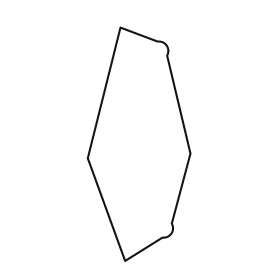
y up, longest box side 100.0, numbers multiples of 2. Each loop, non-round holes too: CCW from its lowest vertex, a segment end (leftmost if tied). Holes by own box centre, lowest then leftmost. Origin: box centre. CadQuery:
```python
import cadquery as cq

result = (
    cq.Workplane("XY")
    .moveTo(-6.0, -50.0)
    .lineTo(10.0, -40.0)
    .threePointArc((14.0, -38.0), (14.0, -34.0))
    .lineTo(22.0, -4.0)
    .lineTo(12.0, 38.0)
    .threePointArc((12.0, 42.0), (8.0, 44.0))
    .lineTo(-8.0, 50.0)
    .lineTo(-22.0, -6.0)
    .close()
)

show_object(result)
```